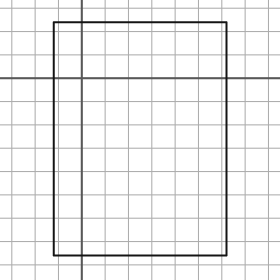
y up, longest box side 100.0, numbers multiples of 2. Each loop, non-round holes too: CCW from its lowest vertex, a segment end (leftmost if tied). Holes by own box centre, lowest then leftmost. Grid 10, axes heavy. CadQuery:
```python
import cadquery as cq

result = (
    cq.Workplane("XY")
    .moveTo(-12.0, -76.0)
    .lineTo(62.0, -76.0)
    .lineTo(62.0, 24.0)
    .lineTo(-12.0, 24.0)
    .close()
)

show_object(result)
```